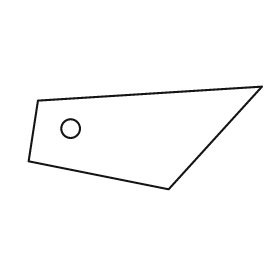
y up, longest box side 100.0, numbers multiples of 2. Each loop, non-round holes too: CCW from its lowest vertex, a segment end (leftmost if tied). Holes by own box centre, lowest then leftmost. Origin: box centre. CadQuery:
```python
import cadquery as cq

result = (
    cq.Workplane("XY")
    .moveTo(10.0, -22.0)
    .lineTo(50.0, 22.0)
    .lineTo(-46.0, 16.0)
    .lineTo(-50.0, -10.0)
    .close()
    .moveTo(-32.0, 4.0)
    .circle(4.0)
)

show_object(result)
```